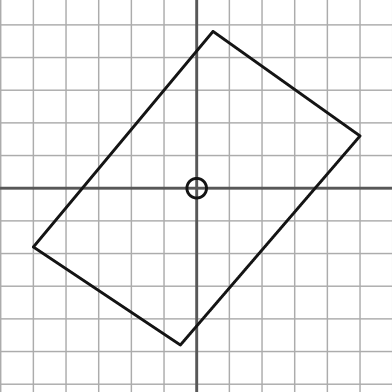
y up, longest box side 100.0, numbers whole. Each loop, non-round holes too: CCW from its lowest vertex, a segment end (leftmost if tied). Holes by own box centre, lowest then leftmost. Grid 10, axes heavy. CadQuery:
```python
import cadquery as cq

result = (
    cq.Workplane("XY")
    .moveTo(-5.0, -48.0)
    .lineTo(50.0, 16.0)
    .lineTo(5.0, 48.0)
    .lineTo(-50.0, -18.0)
    .close()
    .moveTo(0.0, 0.0)
    .circle(3.0)
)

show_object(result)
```